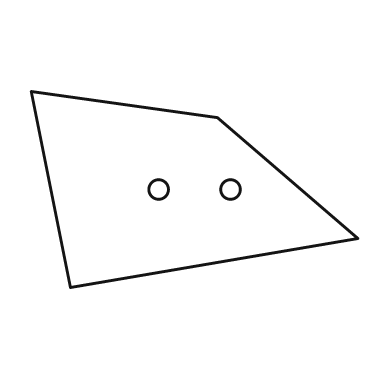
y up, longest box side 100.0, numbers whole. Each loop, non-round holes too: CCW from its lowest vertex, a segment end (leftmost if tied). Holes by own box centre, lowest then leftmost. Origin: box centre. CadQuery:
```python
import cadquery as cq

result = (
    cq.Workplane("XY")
    .moveTo(-38.0, -30.0)
    .lineTo(50.0, -15.0)
    .lineTo(7.0, 22.0)
    .lineTo(-50.0, 30.0)
    .close()
    .moveTo(-11.0, 0.0)
    .circle(3.0)
    .moveTo(11.0, 0.0)
    .circle(3.0)
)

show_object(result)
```